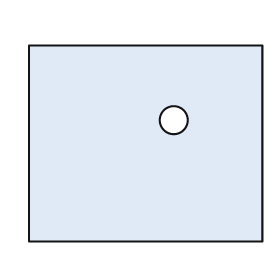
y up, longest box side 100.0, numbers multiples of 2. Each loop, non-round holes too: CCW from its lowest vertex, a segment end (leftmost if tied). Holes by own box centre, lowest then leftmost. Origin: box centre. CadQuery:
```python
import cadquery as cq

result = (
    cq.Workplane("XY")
    .moveTo(-50.0, -42.0)
    .lineTo(50.0, -42.0)
    .lineTo(50.0, 42.0)
    .lineTo(-50.0, 42.0)
    .close()
    .moveTo(12.0, 10.0)
    .circle(6.0)
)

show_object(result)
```